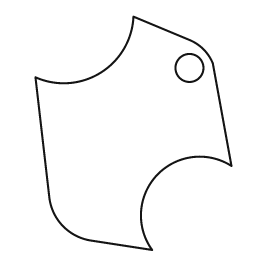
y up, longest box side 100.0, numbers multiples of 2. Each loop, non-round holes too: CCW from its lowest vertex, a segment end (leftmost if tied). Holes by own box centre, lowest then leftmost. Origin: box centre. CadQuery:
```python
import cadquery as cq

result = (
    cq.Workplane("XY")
    .moveTo(8.0, -50.0)
    .threePointArc((10.0, -18.0), (42.0, -14.0))
    .lineTo(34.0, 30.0)
    .threePointArc((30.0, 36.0), (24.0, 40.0))
    .lineTo(0.0, 50.0)
    .threePointArc((-14.0, 26.0), (-42.0, 24.0))
    .lineTo(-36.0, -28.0)
    .threePointArc((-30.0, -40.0), (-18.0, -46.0))
    .close()
    .moveTo(24.0, 28.0)
    .circle(6.0)
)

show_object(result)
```